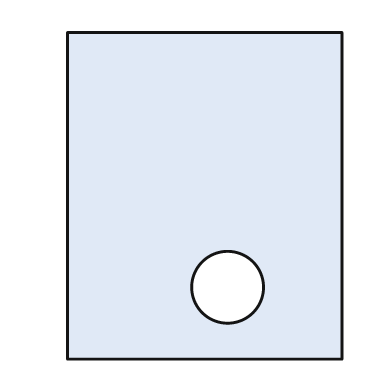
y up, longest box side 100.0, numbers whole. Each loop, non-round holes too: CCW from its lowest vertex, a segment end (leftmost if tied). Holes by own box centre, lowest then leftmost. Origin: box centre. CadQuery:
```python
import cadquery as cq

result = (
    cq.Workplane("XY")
    .moveTo(-42.0, -50.0)
    .lineTo(42.0, -50.0)
    .lineTo(42.0, 50.0)
    .lineTo(-42.0, 50.0)
    .close()
    .moveTo(7.0, -28.0)
    .circle(11.0)
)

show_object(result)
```